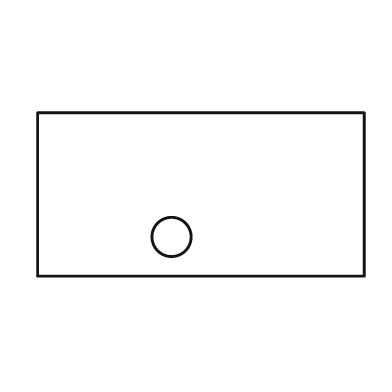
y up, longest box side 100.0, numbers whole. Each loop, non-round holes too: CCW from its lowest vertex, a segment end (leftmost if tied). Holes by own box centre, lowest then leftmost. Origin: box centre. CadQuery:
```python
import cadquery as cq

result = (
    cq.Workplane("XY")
    .moveTo(-50.0, -25.0)
    .lineTo(50.0, -25.0)
    .lineTo(50.0, 25.0)
    .lineTo(-50.0, 25.0)
    .close()
    .moveTo(-9.0, -13.0)
    .circle(6.0)
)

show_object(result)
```